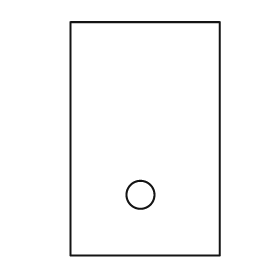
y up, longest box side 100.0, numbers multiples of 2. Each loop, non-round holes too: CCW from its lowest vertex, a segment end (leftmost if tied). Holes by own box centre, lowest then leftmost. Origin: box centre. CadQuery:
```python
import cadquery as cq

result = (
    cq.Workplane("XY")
    .moveTo(-32.0, -50.0)
    .lineTo(32.0, -50.0)
    .lineTo(32.0, 50.0)
    .lineTo(-32.0, 50.0)
    .close()
    .moveTo(-2.0, -24.0)
    .circle(6.0)
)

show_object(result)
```